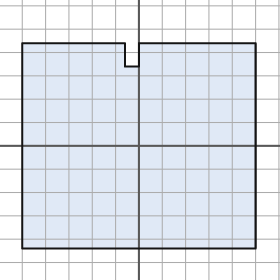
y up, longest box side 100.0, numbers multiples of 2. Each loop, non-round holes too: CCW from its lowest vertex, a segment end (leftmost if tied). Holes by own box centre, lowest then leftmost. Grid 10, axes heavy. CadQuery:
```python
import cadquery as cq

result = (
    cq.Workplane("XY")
    .moveTo(-50.0, -44.0)
    .lineTo(50.0, -44.0)
    .lineTo(50.0, 44.0)
    .lineTo(0.0, 44.0)
    .lineTo(0.0, 34.0)
    .lineTo(-6.0, 34.0)
    .lineTo(-6.0, 44.0)
    .lineTo(-50.0, 44.0)
    .close()
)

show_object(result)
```